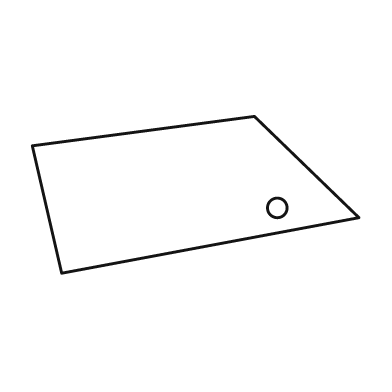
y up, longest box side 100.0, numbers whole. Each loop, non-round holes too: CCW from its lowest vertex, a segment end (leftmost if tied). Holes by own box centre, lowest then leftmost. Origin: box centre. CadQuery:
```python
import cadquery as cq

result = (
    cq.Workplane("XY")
    .moveTo(-41.0, -24.0)
    .lineTo(50.0, -7.0)
    .lineTo(18.0, 24.0)
    .lineTo(-50.0, 15.0)
    .close()
    .moveTo(25.0, -4.0)
    .circle(3.0)
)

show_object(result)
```